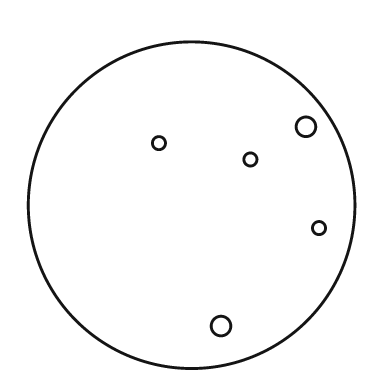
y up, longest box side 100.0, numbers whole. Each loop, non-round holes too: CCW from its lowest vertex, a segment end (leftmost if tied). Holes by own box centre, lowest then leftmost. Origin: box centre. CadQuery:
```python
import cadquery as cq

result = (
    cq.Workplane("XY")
    .moveTo(0.0, 0.0)
    .circle(50.0)
    .moveTo(9.0, -37.0)
    .circle(3.0)
    .moveTo(39.0, -7.0)
    .circle(2.0)
    .moveTo(18.0, 14.0)
    .circle(2.0)
    .moveTo(-10.0, 19.0)
    .circle(2.0)
    .moveTo(35.0, 24.0)
    .circle(3.0)
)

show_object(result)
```